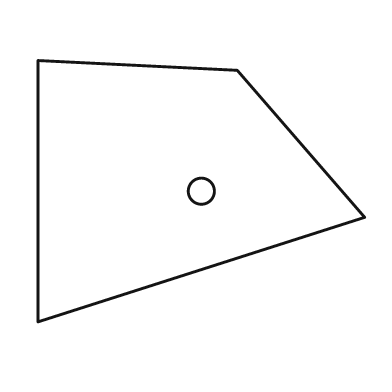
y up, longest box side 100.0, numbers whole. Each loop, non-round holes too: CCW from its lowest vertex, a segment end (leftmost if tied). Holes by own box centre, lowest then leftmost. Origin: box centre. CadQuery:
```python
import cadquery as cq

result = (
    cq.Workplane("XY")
    .moveTo(-50.0, -40.0)
    .lineTo(50.0, -8.0)
    .lineTo(11.0, 37.0)
    .lineTo(-50.0, 40.0)
    .close()
    .moveTo(0.0, 0.0)
    .circle(4.0)
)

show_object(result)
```